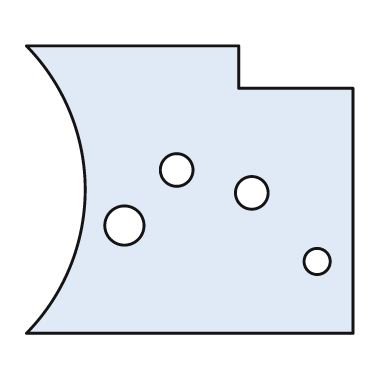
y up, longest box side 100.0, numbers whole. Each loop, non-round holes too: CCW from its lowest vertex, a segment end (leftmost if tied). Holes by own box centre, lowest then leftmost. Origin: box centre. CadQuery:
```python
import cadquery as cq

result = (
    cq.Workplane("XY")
    .moveTo(-50.0, -44.0)
    .lineTo(50.0, -44.0)
    .lineTo(50.0, 31.0)
    .lineTo(15.0, 31.0)
    .lineTo(15.0, 44.0)
    .lineTo(-50.0, 44.0)
    .threePointArc((-32.0, 0.0), (-50.0, -44.0))
    .close()
    .moveTo(39.0, -22.0)
    .circle(4.0)
    .moveTo(-20.0, -11.0)
    .circle(6.0)
    .moveTo(19.0, -1.0)
    .circle(5.0)
    .moveTo(-4.0, 6.0)
    .circle(5.0)
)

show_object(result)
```